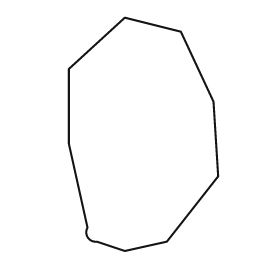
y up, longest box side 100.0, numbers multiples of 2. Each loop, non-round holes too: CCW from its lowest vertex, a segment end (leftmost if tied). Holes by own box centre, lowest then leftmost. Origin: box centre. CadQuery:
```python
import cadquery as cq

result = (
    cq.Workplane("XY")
    .moveTo(-8.0, -50.0)
    .lineTo(10.0, -46.0)
    .lineTo(32.0, -18.0)
    .lineTo(30.0, 14.0)
    .lineTo(16.0, 44.0)
    .lineTo(-8.0, 50.0)
    .lineTo(-32.0, 28.0)
    .lineTo(-32.0, -4.0)
    .lineTo(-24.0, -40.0)
    .threePointArc((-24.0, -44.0), (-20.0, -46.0))
    .close()
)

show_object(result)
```